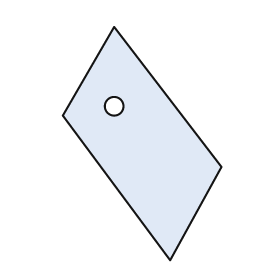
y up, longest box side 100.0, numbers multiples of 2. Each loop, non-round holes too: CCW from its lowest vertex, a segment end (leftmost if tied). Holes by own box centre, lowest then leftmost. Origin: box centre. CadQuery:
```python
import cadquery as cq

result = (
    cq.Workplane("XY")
    .moveTo(12.0, -50.0)
    .lineTo(34.0, -10.0)
    .lineTo(-12.0, 50.0)
    .lineTo(-34.0, 12.0)
    .close()
    .moveTo(-12.0, 16.0)
    .circle(4.0)
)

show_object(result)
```